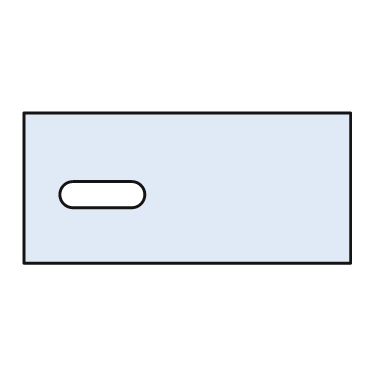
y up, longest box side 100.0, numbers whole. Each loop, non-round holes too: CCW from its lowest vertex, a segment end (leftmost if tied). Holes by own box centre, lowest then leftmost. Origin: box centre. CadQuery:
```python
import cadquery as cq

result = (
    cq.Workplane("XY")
    .moveTo(-50.0, -23.0)
    .lineTo(50.0, -23.0)
    .lineTo(50.0, 23.0)
    .lineTo(-50.0, 23.0)
    .close()
    .moveTo(-35.0, -6.0)
    .lineTo(-17.0, -6.0)
    .threePointArc((-13.0, -2.0), (-17.0, 2.0))
    .lineTo(-35.0, 2.0)
    .threePointArc((-39.0, -2.0), (-35.0, -6.0))
    .close()
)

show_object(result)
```